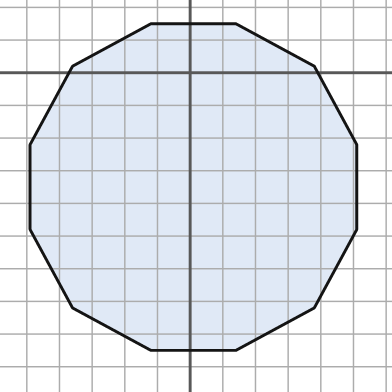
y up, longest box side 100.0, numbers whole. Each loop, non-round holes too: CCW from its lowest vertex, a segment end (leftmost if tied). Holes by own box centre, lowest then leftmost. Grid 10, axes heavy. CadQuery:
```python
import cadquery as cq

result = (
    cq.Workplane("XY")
    .moveTo(-12.0, -85.0)
    .lineTo(14.0, -85.0)
    .lineTo(38.0, -72.0)
    .lineTo(51.0, -48.0)
    .lineTo(51.0, -22.0)
    .lineTo(38.0, 2.0)
    .lineTo(14.0, 15.0)
    .lineTo(-12.0, 15.0)
    .lineTo(-36.0, 2.0)
    .lineTo(-49.0, -22.0)
    .lineTo(-49.0, -48.0)
    .lineTo(-36.0, -72.0)
    .close()
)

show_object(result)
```